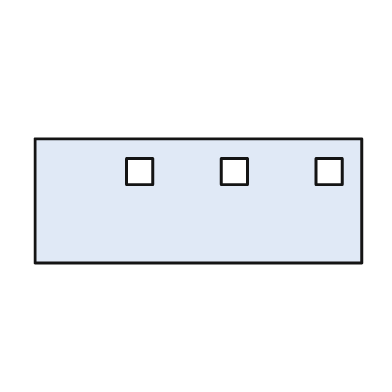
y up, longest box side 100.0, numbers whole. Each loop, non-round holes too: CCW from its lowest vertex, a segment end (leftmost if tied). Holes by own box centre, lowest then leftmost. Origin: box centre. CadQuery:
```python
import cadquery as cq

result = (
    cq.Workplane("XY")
    .moveTo(-50.0, -19.0)
    .lineTo(50.0, -19.0)
    .lineTo(50.0, 19.0)
    .lineTo(-50.0, 19.0)
    .close()
    .moveTo(-22.0, 5.0)
    .lineTo(-14.0, 5.0)
    .lineTo(-14.0, 13.0)
    .lineTo(-22.0, 13.0)
    .close()
    .moveTo(7.0, 5.0)
    .lineTo(15.0, 5.0)
    .lineTo(15.0, 13.0)
    .lineTo(7.0, 13.0)
    .close()
    .moveTo(36.0, 5.0)
    .lineTo(44.0, 5.0)
    .lineTo(44.0, 13.0)
    .lineTo(36.0, 13.0)
    .close()
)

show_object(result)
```